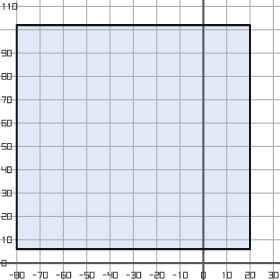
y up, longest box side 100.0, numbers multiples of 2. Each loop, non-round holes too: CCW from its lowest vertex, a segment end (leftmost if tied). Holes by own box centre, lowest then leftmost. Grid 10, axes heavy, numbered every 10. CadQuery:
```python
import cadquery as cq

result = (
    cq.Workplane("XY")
    .moveTo(-80.0, 6.0)
    .lineTo(20.0, 6.0)
    .lineTo(20.0, 102.0)
    .lineTo(-80.0, 102.0)
    .close()
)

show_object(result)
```